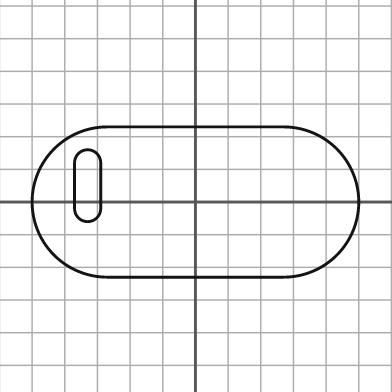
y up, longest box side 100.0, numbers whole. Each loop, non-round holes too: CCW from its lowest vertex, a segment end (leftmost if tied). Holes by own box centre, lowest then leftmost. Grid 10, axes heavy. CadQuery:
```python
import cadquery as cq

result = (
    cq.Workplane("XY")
    .moveTo(-27.0, -23.0)
    .lineTo(27.0, -23.0)
    .threePointArc((50.0, 0.0), (27.0, 23.0))
    .lineTo(-27.0, 23.0)
    .threePointArc((-50.0, 0.0), (-27.0, -23.0))
    .close()
    .moveTo(-37.0, -2.0)
    .threePointArc((-33.0, -6.0), (-29.0, -2.0))
    .lineTo(-29.0, 12.0)
    .threePointArc((-33.0, 16.0), (-37.0, 12.0))
    .close()
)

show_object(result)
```